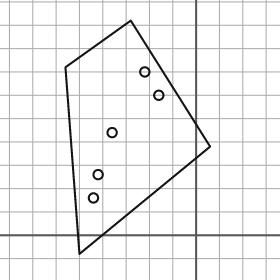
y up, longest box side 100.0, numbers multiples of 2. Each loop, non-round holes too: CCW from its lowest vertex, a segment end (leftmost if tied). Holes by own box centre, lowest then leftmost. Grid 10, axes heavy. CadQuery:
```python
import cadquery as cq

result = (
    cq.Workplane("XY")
    .moveTo(-50.0, -8.0)
    .lineTo(6.0, 38.0)
    .lineTo(-28.0, 92.0)
    .lineTo(-56.0, 72.0)
    .close()
    .moveTo(-44.0, 16.0)
    .circle(2.0)
    .moveTo(-42.0, 26.0)
    .circle(2.0)
    .moveTo(-36.0, 44.0)
    .circle(2.0)
    .moveTo(-16.0, 60.0)
    .circle(2.0)
    .moveTo(-22.0, 70.0)
    .circle(2.0)
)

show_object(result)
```